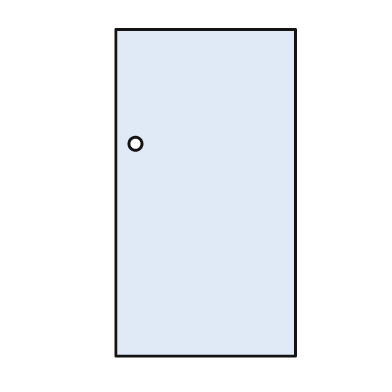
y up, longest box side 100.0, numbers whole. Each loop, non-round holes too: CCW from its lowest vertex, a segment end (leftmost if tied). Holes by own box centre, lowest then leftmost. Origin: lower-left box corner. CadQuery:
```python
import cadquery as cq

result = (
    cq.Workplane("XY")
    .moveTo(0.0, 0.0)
    .lineTo(55.0, 0.0)
    .lineTo(55.0, 100.0)
    .lineTo(0.0, 100.0)
    .close()
    .moveTo(6.0, 65.0)
    .circle(2.0)
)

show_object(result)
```